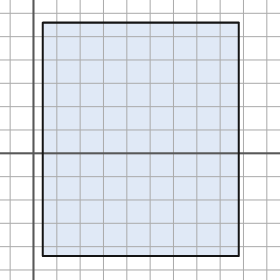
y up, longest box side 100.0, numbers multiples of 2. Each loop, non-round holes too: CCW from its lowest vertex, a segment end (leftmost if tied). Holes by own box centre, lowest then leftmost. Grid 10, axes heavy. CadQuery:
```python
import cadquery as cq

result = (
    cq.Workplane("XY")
    .moveTo(4.0, -44.0)
    .lineTo(88.0, -44.0)
    .lineTo(88.0, 56.0)
    .lineTo(4.0, 56.0)
    .close()
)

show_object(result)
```